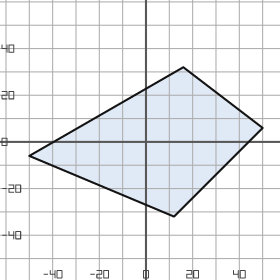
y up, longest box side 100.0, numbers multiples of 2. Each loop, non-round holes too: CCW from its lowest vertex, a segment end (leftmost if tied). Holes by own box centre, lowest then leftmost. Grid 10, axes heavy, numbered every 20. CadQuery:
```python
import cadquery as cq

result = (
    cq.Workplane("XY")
    .moveTo(12.0, -32.0)
    .lineTo(50.0, 6.0)
    .lineTo(16.0, 32.0)
    .lineTo(-50.0, -6.0)
    .close()
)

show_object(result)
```